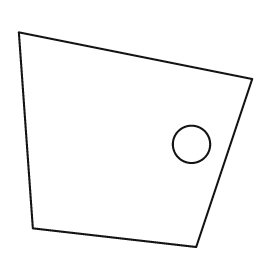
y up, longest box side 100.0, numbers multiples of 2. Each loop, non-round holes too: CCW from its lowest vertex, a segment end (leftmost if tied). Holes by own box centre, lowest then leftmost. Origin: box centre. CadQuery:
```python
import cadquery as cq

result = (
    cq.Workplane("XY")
    .moveTo(26.0, -46.0)
    .lineTo(50.0, 26.0)
    .lineTo(-50.0, 46.0)
    .lineTo(-44.0, -38.0)
    .close()
    .moveTo(24.0, -2.0)
    .circle(8.0)
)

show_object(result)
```